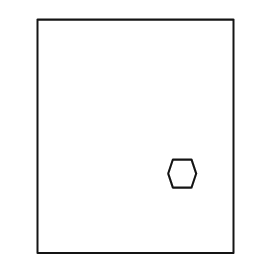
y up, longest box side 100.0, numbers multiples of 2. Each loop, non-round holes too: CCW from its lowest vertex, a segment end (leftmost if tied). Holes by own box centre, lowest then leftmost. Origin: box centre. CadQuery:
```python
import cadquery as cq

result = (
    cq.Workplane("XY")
    .moveTo(-42.0, -50.0)
    .lineTo(42.0, -50.0)
    .lineTo(42.0, 50.0)
    .lineTo(-42.0, 50.0)
    .close()
    .moveTo(16.0, -22.0)
    .lineTo(24.0, -22.0)
    .lineTo(26.0, -16.0)
    .lineTo(24.0, -10.0)
    .lineTo(16.0, -10.0)
    .lineTo(14.0, -16.0)
    .close()
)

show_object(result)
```